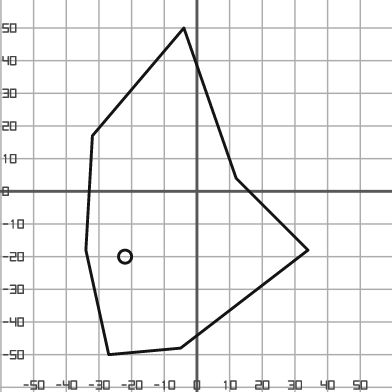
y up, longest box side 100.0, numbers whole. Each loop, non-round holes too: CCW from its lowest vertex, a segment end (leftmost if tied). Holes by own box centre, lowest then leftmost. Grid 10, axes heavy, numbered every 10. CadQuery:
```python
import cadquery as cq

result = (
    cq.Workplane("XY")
    .moveTo(-27.0, -50.0)
    .lineTo(-5.0, -48.0)
    .lineTo(34.0, -18.0)
    .lineTo(12.0, 4.0)
    .lineTo(-4.0, 50.0)
    .lineTo(-32.0, 17.0)
    .lineTo(-34.0, -18.0)
    .close()
    .moveTo(-22.0, -20.0)
    .circle(2.0)
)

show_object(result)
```